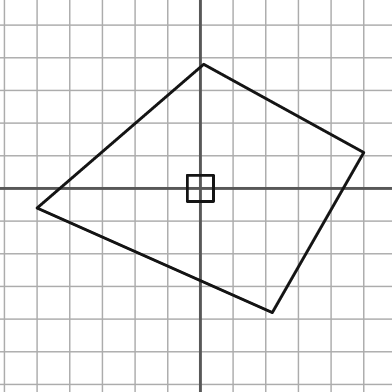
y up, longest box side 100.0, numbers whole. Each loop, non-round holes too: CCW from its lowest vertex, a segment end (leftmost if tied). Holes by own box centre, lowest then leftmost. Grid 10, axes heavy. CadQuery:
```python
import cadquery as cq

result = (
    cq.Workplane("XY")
    .moveTo(22.0, -38.0)
    .lineTo(50.0, 11.0)
    .lineTo(1.0, 38.0)
    .lineTo(-50.0, -6.0)
    .close()
    .moveTo(-4.0, -4.0)
    .lineTo(4.0, -4.0)
    .lineTo(4.0, 4.0)
    .lineTo(-4.0, 4.0)
    .close()
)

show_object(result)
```